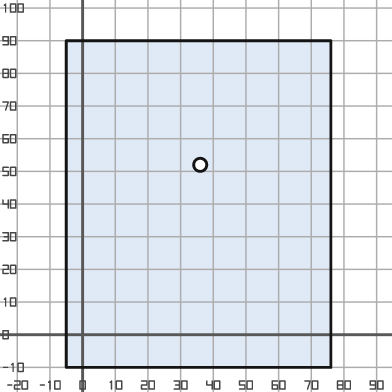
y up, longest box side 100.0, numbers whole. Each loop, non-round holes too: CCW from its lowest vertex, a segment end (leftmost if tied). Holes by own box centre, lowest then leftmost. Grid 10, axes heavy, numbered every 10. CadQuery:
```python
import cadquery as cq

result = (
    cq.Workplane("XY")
    .moveTo(-5.0, -10.0)
    .lineTo(76.0, -10.0)
    .lineTo(76.0, 90.0)
    .lineTo(-5.0, 90.0)
    .close()
    .moveTo(36.0, 52.0)
    .circle(2.0)
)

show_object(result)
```